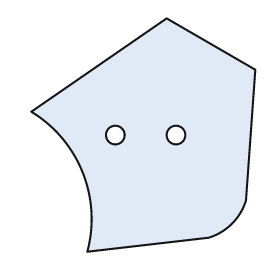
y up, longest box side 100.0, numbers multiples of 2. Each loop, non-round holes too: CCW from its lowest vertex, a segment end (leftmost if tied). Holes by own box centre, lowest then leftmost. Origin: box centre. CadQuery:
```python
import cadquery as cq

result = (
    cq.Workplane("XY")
    .moveTo(-24.0, -50.0)
    .lineTo(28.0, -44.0)
    .threePointArc((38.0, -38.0), (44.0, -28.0))
    .lineTo(48.0, 28.0)
    .lineTo(10.0, 50.0)
    .lineTo(-48.0, 10.0)
    .threePointArc((-26.0, -16.0), (-24.0, -50.0))
    .close()
    .moveTo(-12.0, 0.0)
    .circle(4.0)
    .moveTo(14.0, 0.0)
    .circle(4.0)
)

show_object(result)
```